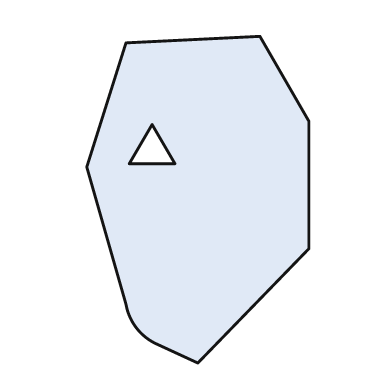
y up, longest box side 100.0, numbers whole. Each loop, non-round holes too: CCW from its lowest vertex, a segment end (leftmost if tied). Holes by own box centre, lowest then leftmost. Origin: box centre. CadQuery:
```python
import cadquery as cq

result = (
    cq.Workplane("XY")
    .moveTo(0.0, -50.0)
    .lineTo(34.0, -15.0)
    .lineTo(34.0, 24.0)
    .lineTo(19.0, 50.0)
    .lineTo(-22.0, 48.0)
    .lineTo(-34.0, 10.0)
    .lineTo(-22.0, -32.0)
    .threePointArc((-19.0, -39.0), (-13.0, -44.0))
    .close()
    .moveTo(-21.0, 11.0)
    .lineTo(-7.0, 11.0)
    .lineTo(-14.0, 23.0)
    .close()
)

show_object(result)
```